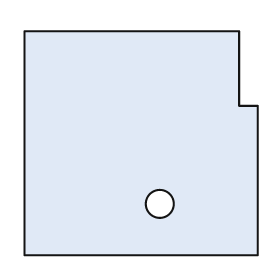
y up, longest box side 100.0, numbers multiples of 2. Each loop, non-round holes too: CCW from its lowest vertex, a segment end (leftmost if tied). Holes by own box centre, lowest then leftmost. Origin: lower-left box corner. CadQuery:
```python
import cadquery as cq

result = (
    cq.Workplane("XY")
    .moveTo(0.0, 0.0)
    .lineTo(100.0, 0.0)
    .lineTo(100.0, 64.0)
    .lineTo(92.0, 64.0)
    .lineTo(92.0, 96.0)
    .lineTo(0.0, 96.0)
    .close()
    .moveTo(58.0, 22.0)
    .circle(6.0)
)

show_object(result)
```